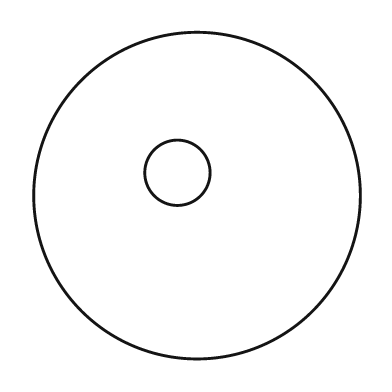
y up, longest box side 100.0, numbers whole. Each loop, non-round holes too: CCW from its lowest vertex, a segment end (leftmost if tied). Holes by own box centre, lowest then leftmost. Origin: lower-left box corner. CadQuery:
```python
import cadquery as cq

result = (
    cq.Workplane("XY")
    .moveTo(50.0, 50.0)
    .circle(50.0)
    .moveTo(44.0, 57.0)
    .circle(10.0)
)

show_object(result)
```